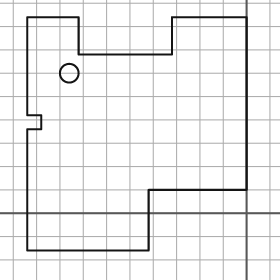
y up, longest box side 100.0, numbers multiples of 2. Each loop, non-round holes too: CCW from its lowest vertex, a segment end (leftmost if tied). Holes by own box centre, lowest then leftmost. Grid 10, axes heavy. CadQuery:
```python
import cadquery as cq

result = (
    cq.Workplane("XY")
    .moveTo(-94.0, -16.0)
    .lineTo(-42.0, -16.0)
    .lineTo(-42.0, 10.0)
    .lineTo(0.0, 10.0)
    .lineTo(0.0, 84.0)
    .lineTo(-32.0, 84.0)
    .lineTo(-32.0, 68.0)
    .lineTo(-72.0, 68.0)
    .lineTo(-72.0, 84.0)
    .lineTo(-94.0, 84.0)
    .lineTo(-94.0, 42.0)
    .lineTo(-88.0, 42.0)
    .lineTo(-88.0, 36.0)
    .lineTo(-94.0, 36.0)
    .close()
    .moveTo(-76.0, 60.0)
    .circle(4.0)
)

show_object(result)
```